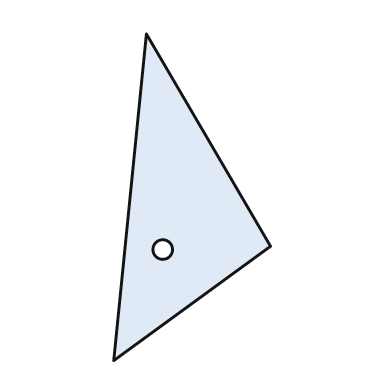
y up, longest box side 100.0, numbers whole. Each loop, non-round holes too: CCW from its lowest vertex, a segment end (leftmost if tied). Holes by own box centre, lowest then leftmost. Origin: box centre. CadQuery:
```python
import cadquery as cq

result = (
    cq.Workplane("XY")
    .moveTo(-24.0, -50.0)
    .lineTo(24.0, -15.0)
    .lineTo(-14.0, 50.0)
    .close()
    .moveTo(-9.0, -16.0)
    .circle(3.0)
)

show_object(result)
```